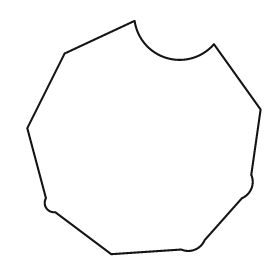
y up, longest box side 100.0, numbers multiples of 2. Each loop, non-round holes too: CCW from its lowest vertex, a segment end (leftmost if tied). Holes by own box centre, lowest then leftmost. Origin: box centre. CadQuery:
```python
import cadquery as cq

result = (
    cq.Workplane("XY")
    .moveTo(-14.0, -50.0)
    .lineTo(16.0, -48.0)
    .threePointArc((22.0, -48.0), (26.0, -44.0))
    .lineTo(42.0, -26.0)
    .threePointArc((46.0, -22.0), (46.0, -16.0))
    .lineTo(50.0, 12.0)
    .lineTo(30.0, 40.0)
    .threePointArc((10.0, 34.0), (-4.0, 50.0))
    .lineTo(-34.0, 36.0)
    .lineTo(-50.0, 4.0)
    .lineTo(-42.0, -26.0)
    .threePointArc((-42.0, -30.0), (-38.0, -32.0))
    .close()
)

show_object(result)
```